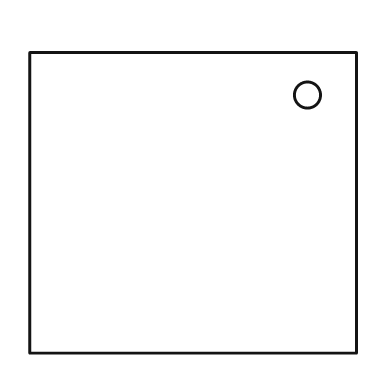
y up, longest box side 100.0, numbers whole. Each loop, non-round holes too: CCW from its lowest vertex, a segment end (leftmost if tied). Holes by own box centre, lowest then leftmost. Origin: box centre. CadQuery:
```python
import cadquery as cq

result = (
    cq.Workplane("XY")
    .moveTo(-50.0, -46.0)
    .lineTo(50.0, -46.0)
    .lineTo(50.0, 46.0)
    .lineTo(-50.0, 46.0)
    .close()
    .moveTo(35.0, 33.0)
    .circle(4.0)
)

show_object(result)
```